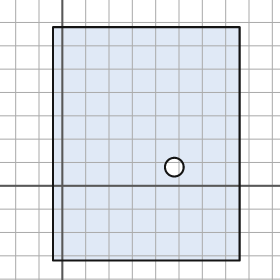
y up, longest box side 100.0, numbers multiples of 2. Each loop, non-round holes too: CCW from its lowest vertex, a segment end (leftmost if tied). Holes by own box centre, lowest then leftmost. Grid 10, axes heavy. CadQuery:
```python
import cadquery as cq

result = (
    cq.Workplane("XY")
    .moveTo(-4.0, -32.0)
    .lineTo(76.0, -32.0)
    .lineTo(76.0, 68.0)
    .lineTo(-4.0, 68.0)
    .close()
    .moveTo(48.0, 8.0)
    .circle(4.0)
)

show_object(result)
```